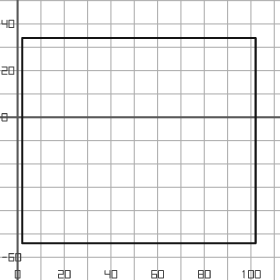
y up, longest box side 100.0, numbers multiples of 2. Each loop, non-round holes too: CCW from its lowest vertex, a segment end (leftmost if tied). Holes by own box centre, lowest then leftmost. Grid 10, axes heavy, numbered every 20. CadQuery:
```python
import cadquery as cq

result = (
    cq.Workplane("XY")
    .moveTo(2.0, -54.0)
    .lineTo(102.0, -54.0)
    .lineTo(102.0, 34.0)
    .lineTo(2.0, 34.0)
    .close()
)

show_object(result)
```